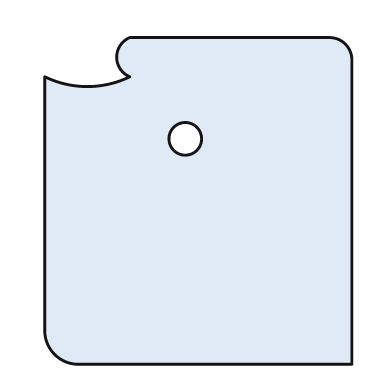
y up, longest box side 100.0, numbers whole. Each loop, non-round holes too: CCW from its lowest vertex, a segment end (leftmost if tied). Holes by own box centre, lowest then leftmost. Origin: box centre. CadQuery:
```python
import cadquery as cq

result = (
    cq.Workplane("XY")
    .moveTo(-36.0, -50.0)
    .lineTo(47.0, -50.0)
    .lineTo(47.0, 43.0)
    .threePointArc((45.0, 48.0), (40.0, 50.0))
    .lineTo(-21.0, 50.0)
    .threePointArc((-25.0, 44.0), (-21.0, 38.0))
    .threePointArc((-34.0, 35.0), (-47.0, 38.0))
    .lineTo(-47.0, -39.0)
    .threePointArc((-44.0, -47.0), (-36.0, -50.0))
    .close()
    .moveTo(-4.0, 19.0)
    .circle(5.0)
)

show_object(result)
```